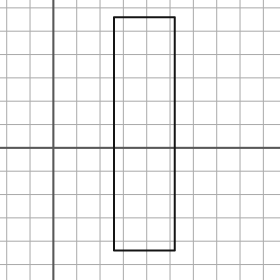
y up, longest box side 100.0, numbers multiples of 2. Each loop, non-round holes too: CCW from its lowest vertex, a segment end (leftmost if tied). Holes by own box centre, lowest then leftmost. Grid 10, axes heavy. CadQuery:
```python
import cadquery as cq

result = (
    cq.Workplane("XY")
    .moveTo(26.0, -44.0)
    .lineTo(52.0, -44.0)
    .lineTo(52.0, 56.0)
    .lineTo(26.0, 56.0)
    .close()
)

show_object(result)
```